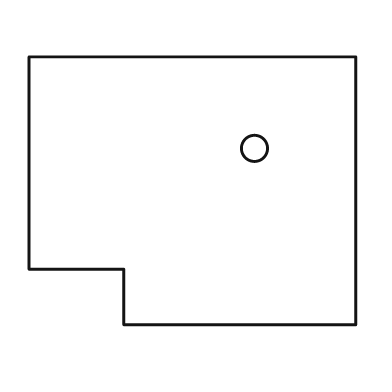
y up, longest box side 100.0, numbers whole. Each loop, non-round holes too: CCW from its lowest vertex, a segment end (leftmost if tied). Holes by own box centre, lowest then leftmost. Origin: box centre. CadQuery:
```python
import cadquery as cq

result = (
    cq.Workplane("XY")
    .moveTo(-21.0, -41.0)
    .lineTo(50.0, -41.0)
    .lineTo(50.0, 41.0)
    .lineTo(-50.0, 41.0)
    .lineTo(-50.0, -24.0)
    .lineTo(-21.0, -24.0)
    .close()
    .moveTo(19.0, 13.0)
    .circle(4.0)
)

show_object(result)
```